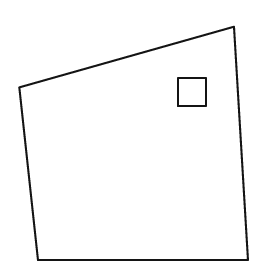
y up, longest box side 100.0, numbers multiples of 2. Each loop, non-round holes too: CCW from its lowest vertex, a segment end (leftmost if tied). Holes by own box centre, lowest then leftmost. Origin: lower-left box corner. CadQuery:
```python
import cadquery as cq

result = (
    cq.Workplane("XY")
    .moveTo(8.0, 0.0)
    .lineTo(98.0, 0.0)
    .lineTo(92.0, 100.0)
    .lineTo(0.0, 74.0)
    .close()
    .moveTo(68.0, 66.0)
    .lineTo(80.0, 66.0)
    .lineTo(80.0, 78.0)
    .lineTo(68.0, 78.0)
    .close()
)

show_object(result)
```